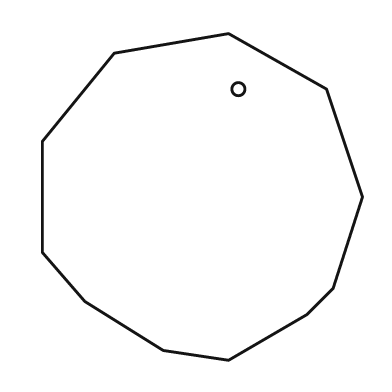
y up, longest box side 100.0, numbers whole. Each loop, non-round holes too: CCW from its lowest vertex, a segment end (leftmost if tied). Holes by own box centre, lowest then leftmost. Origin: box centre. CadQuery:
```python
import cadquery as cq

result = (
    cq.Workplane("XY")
    .moveTo(8.0, -50.0)
    .lineTo(32.0, -36.0)
    .lineTo(40.0, -28.0)
    .lineTo(49.0, 0.0)
    .lineTo(38.0, 33.0)
    .lineTo(8.0, 50.0)
    .lineTo(-27.0, 44.0)
    .lineTo(-49.0, 17.0)
    .lineTo(-49.0, -17.0)
    .lineTo(-36.0, -32.0)
    .lineTo(-12.0, -47.0)
    .close()
    .moveTo(11.0, 33.0)
    .circle(2.0)
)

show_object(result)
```